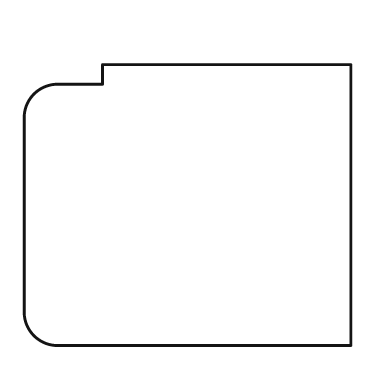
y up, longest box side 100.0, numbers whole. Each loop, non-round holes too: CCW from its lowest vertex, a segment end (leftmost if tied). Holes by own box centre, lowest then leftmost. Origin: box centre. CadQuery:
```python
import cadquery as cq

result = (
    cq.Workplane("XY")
    .moveTo(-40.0, -43.0)
    .lineTo(50.0, -43.0)
    .lineTo(50.0, 43.0)
    .lineTo(-26.0, 43.0)
    .lineTo(-26.0, 37.0)
    .lineTo(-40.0, 37.0)
    .threePointArc((-47.0, 34.0), (-50.0, 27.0))
    .lineTo(-50.0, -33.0)
    .threePointArc((-47.0, -40.0), (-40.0, -43.0))
    .close()
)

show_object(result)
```